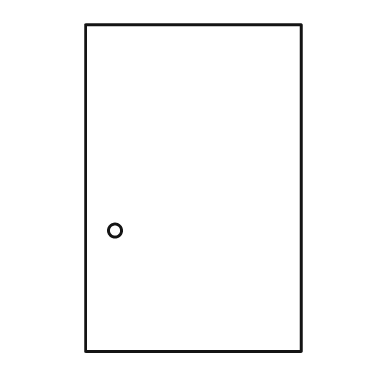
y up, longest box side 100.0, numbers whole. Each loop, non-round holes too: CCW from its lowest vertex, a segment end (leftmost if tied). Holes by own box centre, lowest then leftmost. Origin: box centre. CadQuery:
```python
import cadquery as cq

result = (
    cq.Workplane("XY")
    .moveTo(-33.0, -50.0)
    .lineTo(33.0, -50.0)
    .lineTo(33.0, 50.0)
    .lineTo(-33.0, 50.0)
    .close()
    .moveTo(-24.0, -13.0)
    .circle(2.0)
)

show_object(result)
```